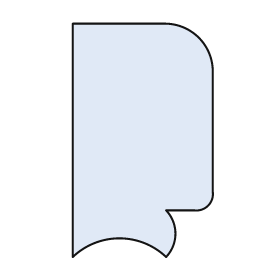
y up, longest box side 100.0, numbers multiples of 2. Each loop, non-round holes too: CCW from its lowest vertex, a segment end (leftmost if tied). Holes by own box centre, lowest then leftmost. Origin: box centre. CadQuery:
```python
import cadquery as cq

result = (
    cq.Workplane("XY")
    .moveTo(-30.0, -50.0)
    .threePointArc((-10.0, -42.0), (10.0, -50.0))
    .threePointArc((14.0, -40.0), (10.0, -30.0))
    .lineTo(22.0, -30.0)
    .threePointArc((28.0, -28.0), (30.0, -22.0))
    .lineTo(30.0, 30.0)
    .threePointArc((24.0, 44.0), (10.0, 50.0))
    .lineTo(-30.0, 50.0)
    .close()
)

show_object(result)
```